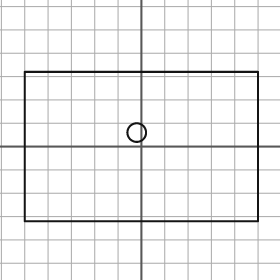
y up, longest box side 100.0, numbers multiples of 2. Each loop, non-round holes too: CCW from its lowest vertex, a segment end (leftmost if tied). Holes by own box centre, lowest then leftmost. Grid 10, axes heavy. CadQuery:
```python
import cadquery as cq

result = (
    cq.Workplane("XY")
    .moveTo(-50.0, -32.0)
    .lineTo(50.0, -32.0)
    .lineTo(50.0, 32.0)
    .lineTo(-50.0, 32.0)
    .close()
    .moveTo(-2.0, 6.0)
    .circle(4.0)
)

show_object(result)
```